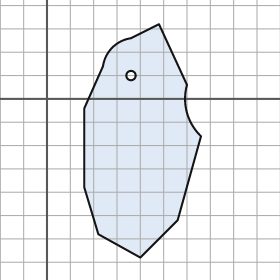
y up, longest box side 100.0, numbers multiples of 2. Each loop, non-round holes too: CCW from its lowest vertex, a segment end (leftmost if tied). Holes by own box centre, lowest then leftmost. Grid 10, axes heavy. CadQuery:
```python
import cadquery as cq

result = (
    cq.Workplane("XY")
    .moveTo(40.0, -68.0)
    .lineTo(56.0, -52.0)
    .lineTo(66.0, -16.0)
    .threePointArc((60.0, -6.0), (60.0, 6.0))
    .lineTo(48.0, 32.0)
    .lineTo(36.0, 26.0)
    .threePointArc((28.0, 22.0), (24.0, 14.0))
    .lineTo(16.0, -4.0)
    .lineTo(16.0, -38.0)
    .lineTo(22.0, -58.0)
    .close()
    .moveTo(36.0, 10.0)
    .circle(2.0)
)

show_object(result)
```